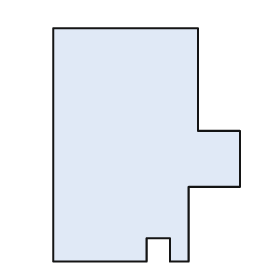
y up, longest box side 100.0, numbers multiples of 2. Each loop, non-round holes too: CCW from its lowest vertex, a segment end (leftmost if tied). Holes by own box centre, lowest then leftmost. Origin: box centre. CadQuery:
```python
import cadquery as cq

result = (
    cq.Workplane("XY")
    .moveTo(-40.0, -50.0)
    .lineTo(0.0, -50.0)
    .lineTo(0.0, -40.0)
    .lineTo(10.0, -40.0)
    .lineTo(10.0, -50.0)
    .lineTo(18.0, -50.0)
    .lineTo(18.0, -18.0)
    .lineTo(40.0, -18.0)
    .lineTo(40.0, 6.0)
    .lineTo(22.0, 6.0)
    .lineTo(22.0, 50.0)
    .lineTo(-40.0, 50.0)
    .close()
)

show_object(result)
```